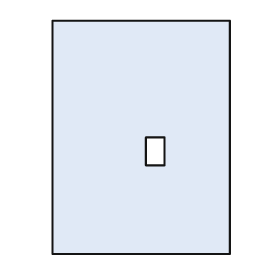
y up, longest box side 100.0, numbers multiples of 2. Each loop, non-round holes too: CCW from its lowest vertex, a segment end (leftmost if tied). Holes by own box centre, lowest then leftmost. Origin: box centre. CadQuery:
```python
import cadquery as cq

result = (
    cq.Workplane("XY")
    .moveTo(-38.0, -50.0)
    .lineTo(38.0, -50.0)
    .lineTo(38.0, 50.0)
    .lineTo(-38.0, 50.0)
    .close()
    .moveTo(2.0, -12.0)
    .lineTo(10.0, -12.0)
    .lineTo(10.0, 0.0)
    .lineTo(2.0, 0.0)
    .close()
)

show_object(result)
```